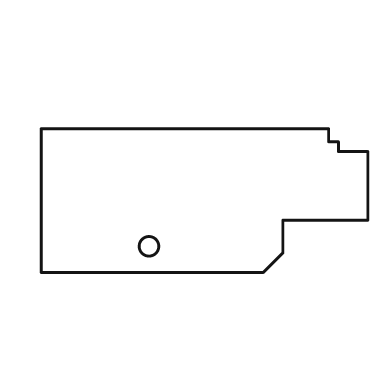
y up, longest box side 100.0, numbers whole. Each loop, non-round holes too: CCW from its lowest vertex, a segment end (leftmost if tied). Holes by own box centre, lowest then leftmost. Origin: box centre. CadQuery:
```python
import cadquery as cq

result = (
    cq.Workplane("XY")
    .moveTo(-50.0, -22.0)
    .lineTo(18.0, -22.0)
    .lineTo(24.0, -16.0)
    .lineTo(24.0, -6.0)
    .lineTo(50.0, -6.0)
    .lineTo(50.0, 15.0)
    .lineTo(41.0, 15.0)
    .lineTo(41.0, 18.0)
    .lineTo(38.0, 18.0)
    .lineTo(38.0, 22.0)
    .lineTo(-50.0, 22.0)
    .close()
    .moveTo(-17.0, -14.0)
    .circle(3.0)
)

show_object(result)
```